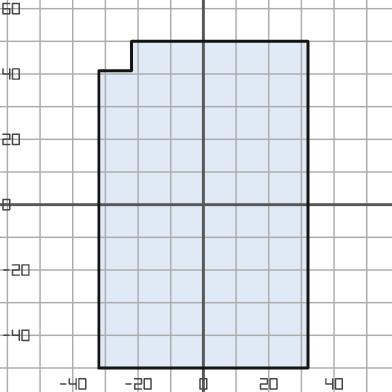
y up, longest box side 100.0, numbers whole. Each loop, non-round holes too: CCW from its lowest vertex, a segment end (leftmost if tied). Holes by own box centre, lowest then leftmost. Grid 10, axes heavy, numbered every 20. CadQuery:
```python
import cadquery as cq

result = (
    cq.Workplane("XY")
    .moveTo(-32.0, -50.0)
    .lineTo(32.0, -50.0)
    .lineTo(32.0, 50.0)
    .lineTo(-22.0, 50.0)
    .lineTo(-22.0, 41.0)
    .lineTo(-32.0, 41.0)
    .close()
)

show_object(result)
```